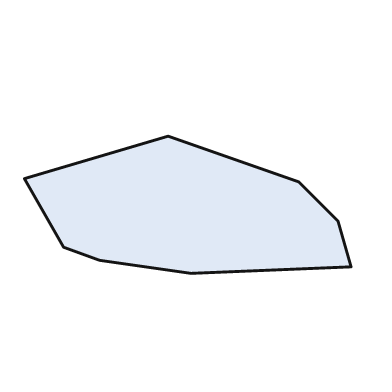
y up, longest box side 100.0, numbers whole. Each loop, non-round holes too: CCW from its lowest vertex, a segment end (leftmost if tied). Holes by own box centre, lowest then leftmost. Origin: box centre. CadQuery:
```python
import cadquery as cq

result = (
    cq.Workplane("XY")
    .moveTo(1.0, -21.0)
    .lineTo(50.0, -19.0)
    .lineTo(46.0, -5.0)
    .lineTo(34.0, 7.0)
    .lineTo(-6.0, 21.0)
    .lineTo(-50.0, 8.0)
    .lineTo(-38.0, -13.0)
    .lineTo(-27.0, -17.0)
    .close()
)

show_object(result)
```